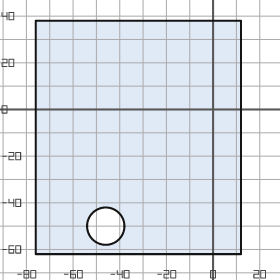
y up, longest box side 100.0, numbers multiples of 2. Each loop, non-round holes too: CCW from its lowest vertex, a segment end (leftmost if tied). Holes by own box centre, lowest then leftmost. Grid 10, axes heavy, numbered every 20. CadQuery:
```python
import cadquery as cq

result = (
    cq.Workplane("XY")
    .moveTo(-76.0, -62.0)
    .lineTo(12.0, -62.0)
    .lineTo(12.0, 38.0)
    .lineTo(-76.0, 38.0)
    .close()
    .moveTo(-46.0, -50.0)
    .circle(8.0)
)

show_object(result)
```